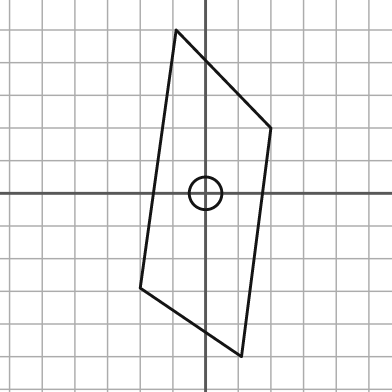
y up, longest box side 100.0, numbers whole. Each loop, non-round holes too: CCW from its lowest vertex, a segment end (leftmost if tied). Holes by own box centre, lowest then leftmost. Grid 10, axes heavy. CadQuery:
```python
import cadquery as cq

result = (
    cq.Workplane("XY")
    .moveTo(11.0, -50.0)
    .lineTo(20.0, 20.0)
    .lineTo(-9.0, 50.0)
    .lineTo(-20.0, -29.0)
    .close()
    .moveTo(0.0, 0.0)
    .circle(5.0)
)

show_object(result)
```